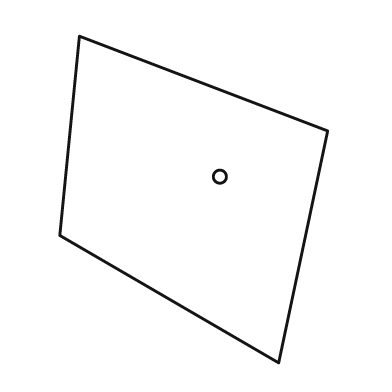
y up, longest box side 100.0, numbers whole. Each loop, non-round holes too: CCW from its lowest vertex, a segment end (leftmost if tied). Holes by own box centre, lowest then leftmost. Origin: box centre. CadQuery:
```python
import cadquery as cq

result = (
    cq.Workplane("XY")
    .moveTo(26.0, -50.0)
    .lineTo(41.0, 21.0)
    .lineTo(-35.0, 50.0)
    .lineTo(-41.0, -11.0)
    .close()
    .moveTo(8.0, 7.0)
    .circle(2.0)
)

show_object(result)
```